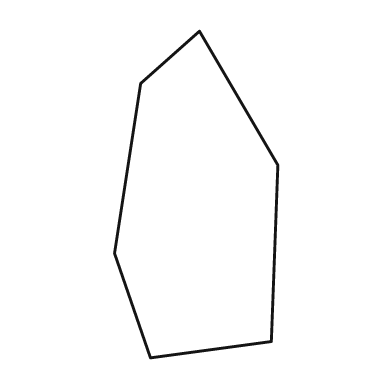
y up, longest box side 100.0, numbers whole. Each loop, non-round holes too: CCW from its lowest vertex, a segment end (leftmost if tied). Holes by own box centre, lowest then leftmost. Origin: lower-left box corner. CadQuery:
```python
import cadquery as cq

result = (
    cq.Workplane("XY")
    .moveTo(11.0, 0.0)
    .lineTo(48.0, 5.0)
    .lineTo(50.0, 59.0)
    .lineTo(26.0, 100.0)
    .lineTo(8.0, 84.0)
    .lineTo(0.0, 32.0)
    .close()
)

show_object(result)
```